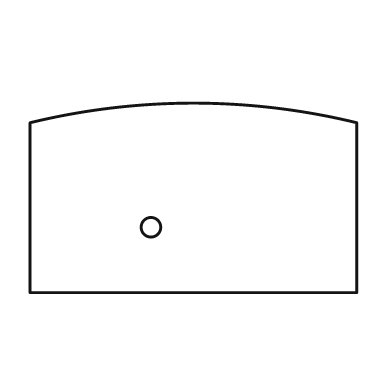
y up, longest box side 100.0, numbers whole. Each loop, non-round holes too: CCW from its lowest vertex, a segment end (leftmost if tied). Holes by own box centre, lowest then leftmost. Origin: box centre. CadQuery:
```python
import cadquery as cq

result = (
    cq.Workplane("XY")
    .moveTo(-50.0, -29.0)
    .lineTo(50.0, -29.0)
    .lineTo(50.0, 23.0)
    .threePointArc((0.0, 29.0), (-50.0, 23.0))
    .close()
    .moveTo(-13.0, -9.0)
    .circle(3.0)
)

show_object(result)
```